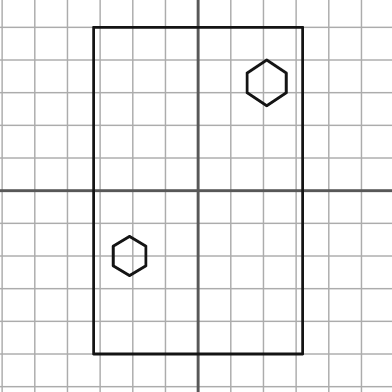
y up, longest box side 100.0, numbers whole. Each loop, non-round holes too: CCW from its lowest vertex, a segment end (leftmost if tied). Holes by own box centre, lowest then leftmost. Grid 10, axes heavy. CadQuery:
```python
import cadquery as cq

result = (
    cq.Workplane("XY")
    .moveTo(-32.0, -50.0)
    .lineTo(32.0, -50.0)
    .lineTo(32.0, 50.0)
    .lineTo(-32.0, 50.0)
    .close()
    .moveTo(-21.0, -26.0)
    .lineTo(-16.0, -23.0)
    .lineTo(-16.0, -17.0)
    .lineTo(-21.0, -14.0)
    .lineTo(-26.0, -17.0)
    .lineTo(-26.0, -23.0)
    .close()
    .moveTo(21.0, 26.0)
    .lineTo(27.0, 30.0)
    .lineTo(27.0, 36.0)
    .lineTo(21.0, 40.0)
    .lineTo(15.0, 36.0)
    .lineTo(15.0, 30.0)
    .close()
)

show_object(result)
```